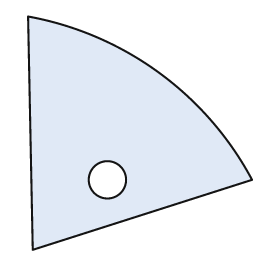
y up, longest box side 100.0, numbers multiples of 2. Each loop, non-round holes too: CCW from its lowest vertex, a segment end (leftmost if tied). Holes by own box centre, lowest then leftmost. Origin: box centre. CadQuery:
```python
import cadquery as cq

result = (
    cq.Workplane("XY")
    .moveTo(-46.0, -50.0)
    .lineTo(48.0, -20.0)
    .threePointArc((8.0, 26.0), (-48.0, 50.0))
    .close()
    .moveTo(-14.0, -20.0)
    .circle(8.0)
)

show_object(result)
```